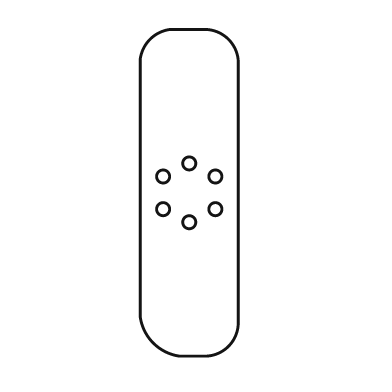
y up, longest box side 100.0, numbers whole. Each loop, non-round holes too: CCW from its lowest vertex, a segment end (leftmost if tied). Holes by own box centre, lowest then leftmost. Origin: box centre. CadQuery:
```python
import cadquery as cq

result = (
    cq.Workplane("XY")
    .moveTo(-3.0, -50.0)
    .lineTo(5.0, -50.0)
    .threePointArc((12.0, -47.0), (15.0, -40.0))
    .lineTo(15.0, 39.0)
    .threePointArc((12.0, 47.0), (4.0, 50.0))
    .lineTo(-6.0, 50.0)
    .threePointArc((-12.0, 47.0), (-15.0, 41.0))
    .lineTo(-15.0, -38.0)
    .threePointArc((-11.0, -46.0), (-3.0, -50.0))
    .close()
    .moveTo(0.0, -9.0)
    .circle(2.0)
    .moveTo(-8.0, -5.0)
    .circle(2.0)
    .moveTo(8.0, -5.0)
    .circle(2.0)
    .moveTo(-8.0, 5.0)
    .circle(2.0)
    .moveTo(8.0, 5.0)
    .circle(2.0)
    .moveTo(0.0, 9.0)
    .circle(2.0)
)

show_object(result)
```